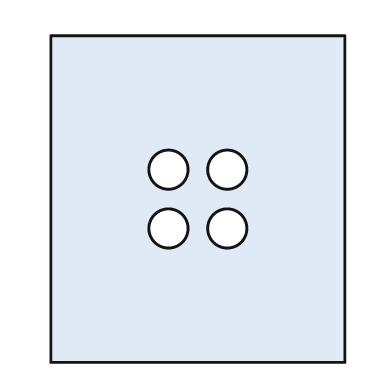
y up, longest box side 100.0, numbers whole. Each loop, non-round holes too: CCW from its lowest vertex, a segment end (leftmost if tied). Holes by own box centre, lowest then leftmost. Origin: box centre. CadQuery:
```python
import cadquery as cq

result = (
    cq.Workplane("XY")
    .moveTo(-45.0, -50.0)
    .lineTo(45.0, -50.0)
    .lineTo(45.0, 50.0)
    .lineTo(-45.0, 50.0)
    .close()
    .moveTo(-9.0, -9.0)
    .circle(6.0)
    .moveTo(9.0, -9.0)
    .circle(6.0)
    .moveTo(-9.0, 9.0)
    .circle(6.0)
    .moveTo(9.0, 9.0)
    .circle(6.0)
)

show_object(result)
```